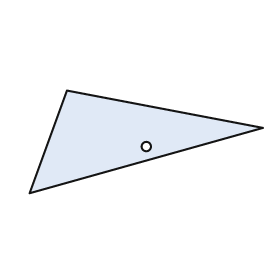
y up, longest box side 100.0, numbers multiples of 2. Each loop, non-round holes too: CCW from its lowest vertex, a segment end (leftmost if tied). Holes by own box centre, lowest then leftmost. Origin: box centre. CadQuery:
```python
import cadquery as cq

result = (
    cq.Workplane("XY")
    .moveTo(-50.0, -22.0)
    .lineTo(50.0, 6.0)
    .lineTo(-34.0, 22.0)
    .close()
    .moveTo(0.0, -2.0)
    .circle(2.0)
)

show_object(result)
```